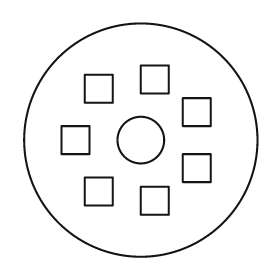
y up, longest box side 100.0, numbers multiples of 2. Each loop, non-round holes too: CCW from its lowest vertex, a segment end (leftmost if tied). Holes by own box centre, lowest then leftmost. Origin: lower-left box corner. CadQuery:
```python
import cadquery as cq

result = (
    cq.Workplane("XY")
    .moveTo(50.0, 50.0)
    .circle(50.0)
    .moveTo(50.0, 18.0)
    .lineTo(62.0, 18.0)
    .lineTo(62.0, 30.0)
    .lineTo(50.0, 30.0)
    .close()
    .moveTo(26.0, 22.0)
    .lineTo(38.0, 22.0)
    .lineTo(38.0, 34.0)
    .lineTo(26.0, 34.0)
    .close()
    .moveTo(68.0, 32.0)
    .lineTo(80.0, 32.0)
    .lineTo(80.0, 44.0)
    .lineTo(68.0, 44.0)
    .close()
    .moveTo(16.0, 44.0)
    .lineTo(28.0, 44.0)
    .lineTo(28.0, 56.0)
    .lineTo(16.0, 56.0)
    .close()
    .moveTo(50.0, 50.0)
    .circle(10.0)
    .moveTo(68.0, 56.0)
    .lineTo(80.0, 56.0)
    .lineTo(80.0, 68.0)
    .lineTo(68.0, 68.0)
    .close()
    .moveTo(26.0, 66.0)
    .lineTo(38.0, 66.0)
    .lineTo(38.0, 78.0)
    .lineTo(26.0, 78.0)
    .close()
    .moveTo(50.0, 70.0)
    .lineTo(62.0, 70.0)
    .lineTo(62.0, 82.0)
    .lineTo(50.0, 82.0)
    .close()
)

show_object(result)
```